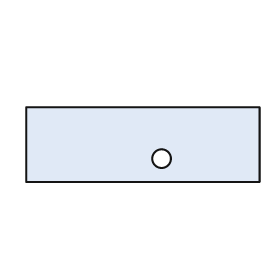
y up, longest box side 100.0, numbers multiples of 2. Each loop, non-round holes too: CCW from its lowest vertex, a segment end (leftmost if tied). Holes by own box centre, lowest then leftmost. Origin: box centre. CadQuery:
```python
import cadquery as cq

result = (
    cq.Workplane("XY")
    .moveTo(-50.0, -16.0)
    .lineTo(50.0, -16.0)
    .lineTo(50.0, 16.0)
    .lineTo(-50.0, 16.0)
    .close()
    .moveTo(8.0, -6.0)
    .circle(4.0)
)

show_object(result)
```